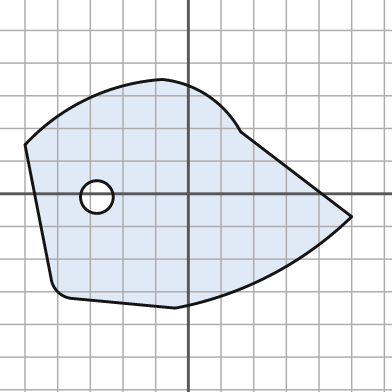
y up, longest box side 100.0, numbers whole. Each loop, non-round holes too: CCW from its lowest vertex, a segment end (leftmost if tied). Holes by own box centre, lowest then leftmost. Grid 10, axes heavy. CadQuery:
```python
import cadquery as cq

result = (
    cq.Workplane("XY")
    .moveTo(-4.0, -35.0)
    .threePointArc((25.0, -25.0), (50.0, -7.0))
    .lineTo(16.0, 19.0)
    .threePointArc((6.0, 30.0), (-8.0, 35.0))
    .threePointArc((-31.0, 29.0), (-50.0, 15.0))
    .lineTo(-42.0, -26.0)
    .threePointArc((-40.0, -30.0), (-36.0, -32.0))
    .close()
    .moveTo(-28.0, -1.0)
    .circle(5.0)
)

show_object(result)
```